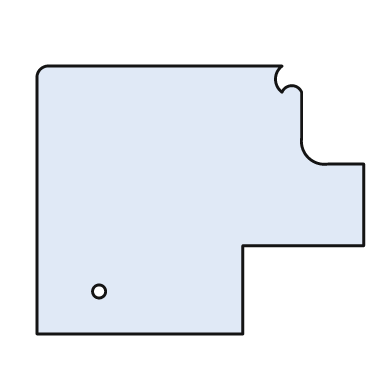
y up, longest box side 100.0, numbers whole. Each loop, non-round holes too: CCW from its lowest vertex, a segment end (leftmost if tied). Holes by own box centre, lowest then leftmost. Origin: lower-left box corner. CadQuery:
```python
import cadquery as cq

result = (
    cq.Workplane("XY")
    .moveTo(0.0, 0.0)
    .lineTo(63.0, 0.0)
    .lineTo(63.0, 27.0)
    .lineTo(100.0, 27.0)
    .lineTo(100.0, 52.0)
    .lineTo(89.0, 52.0)
    .threePointArc((83.0, 54.0), (81.0, 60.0))
    .lineTo(81.0, 74.0)
    .threePointArc((78.0, 76.0), (75.0, 74.0))
    .threePointArc((73.0, 78.0), (75.0, 82.0))
    .lineTo(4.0, 82.0)
    .threePointArc((1.0, 81.0), (0.0, 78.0))
    .close()
    .moveTo(19.0, 13.0)
    .circle(2.0)
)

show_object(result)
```